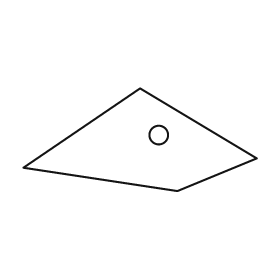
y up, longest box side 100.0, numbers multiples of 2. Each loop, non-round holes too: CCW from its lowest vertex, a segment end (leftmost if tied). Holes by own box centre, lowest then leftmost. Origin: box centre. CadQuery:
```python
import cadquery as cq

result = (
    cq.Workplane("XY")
    .moveTo(16.0, -22.0)
    .lineTo(50.0, -8.0)
    .lineTo(0.0, 22.0)
    .lineTo(-50.0, -12.0)
    .close()
    .moveTo(8.0, 2.0)
    .circle(4.0)
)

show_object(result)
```